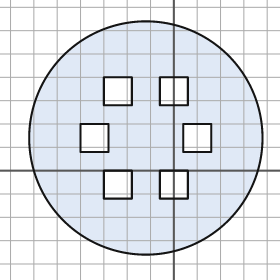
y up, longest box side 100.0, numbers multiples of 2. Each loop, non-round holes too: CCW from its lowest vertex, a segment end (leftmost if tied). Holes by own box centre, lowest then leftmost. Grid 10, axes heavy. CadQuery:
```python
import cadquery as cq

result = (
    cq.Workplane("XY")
    .moveTo(-12.0, 14.0)
    .circle(50.0)
    .moveTo(-30.0, -12.0)
    .lineTo(-18.0, -12.0)
    .lineTo(-18.0, 0.0)
    .lineTo(-30.0, 0.0)
    .close()
    .moveTo(-6.0, -12.0)
    .lineTo(6.0, -12.0)
    .lineTo(6.0, 0.0)
    .lineTo(-6.0, 0.0)
    .close()
    .moveTo(-40.0, 8.0)
    .lineTo(-28.0, 8.0)
    .lineTo(-28.0, 20.0)
    .lineTo(-40.0, 20.0)
    .close()
    .moveTo(4.0, 8.0)
    .lineTo(16.0, 8.0)
    .lineTo(16.0, 20.0)
    .lineTo(4.0, 20.0)
    .close()
    .moveTo(-30.0, 28.0)
    .lineTo(-18.0, 28.0)
    .lineTo(-18.0, 40.0)
    .lineTo(-30.0, 40.0)
    .close()
    .moveTo(-6.0, 28.0)
    .lineTo(6.0, 28.0)
    .lineTo(6.0, 40.0)
    .lineTo(-6.0, 40.0)
    .close()
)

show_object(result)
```